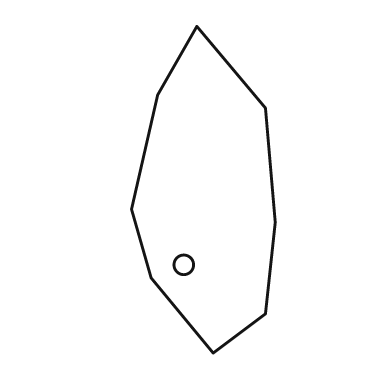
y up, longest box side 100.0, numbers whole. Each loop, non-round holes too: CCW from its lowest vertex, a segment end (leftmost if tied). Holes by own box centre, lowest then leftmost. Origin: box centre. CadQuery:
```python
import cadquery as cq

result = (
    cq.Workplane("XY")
    .moveTo(3.0, -50.0)
    .lineTo(19.0, -38.0)
    .lineTo(22.0, -10.0)
    .lineTo(19.0, 25.0)
    .lineTo(-2.0, 50.0)
    .lineTo(-14.0, 29.0)
    .lineTo(-22.0, -6.0)
    .lineTo(-16.0, -27.0)
    .close()
    .moveTo(-6.0, -23.0)
    .circle(3.0)
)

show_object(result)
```